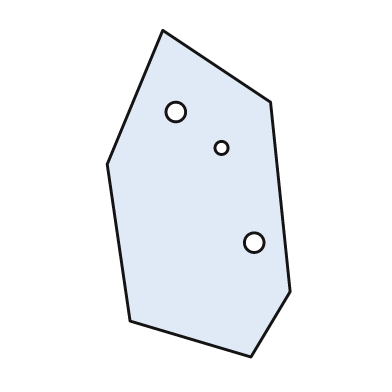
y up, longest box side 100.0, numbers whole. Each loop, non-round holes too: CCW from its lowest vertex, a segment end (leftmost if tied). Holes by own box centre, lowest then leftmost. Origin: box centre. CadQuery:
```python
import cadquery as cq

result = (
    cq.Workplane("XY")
    .moveTo(16.0, -50.0)
    .lineTo(28.0, -30.0)
    .lineTo(22.0, 28.0)
    .lineTo(-11.0, 50.0)
    .lineTo(-28.0, 9.0)
    .lineTo(-21.0, -39.0)
    .close()
    .moveTo(17.0, -15.0)
    .circle(3.0)
    .moveTo(7.0, 14.0)
    .circle(2.0)
    .moveTo(-7.0, 25.0)
    .circle(3.0)
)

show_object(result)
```